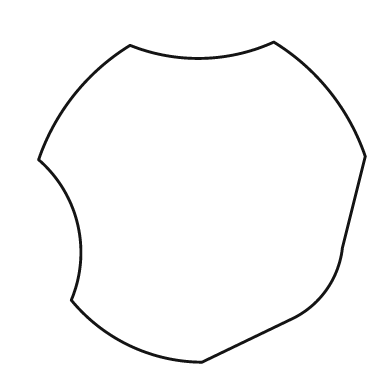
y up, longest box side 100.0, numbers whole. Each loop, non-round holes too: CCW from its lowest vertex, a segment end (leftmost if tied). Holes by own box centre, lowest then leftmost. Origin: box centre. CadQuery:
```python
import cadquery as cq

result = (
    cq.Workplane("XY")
    .moveTo(0.0, -49.0)
    .lineTo(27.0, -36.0)
    .threePointArc((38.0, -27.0), (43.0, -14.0))
    .lineTo(50.0, 14.0)
    .threePointArc((39.0, 34.0), (22.0, 49.0))
    .threePointArc((0.0, 44.0), (-22.0, 48.0))
    .threePointArc((-39.0, 33.0), (-50.0, 13.0))
    .threePointArc((-38.0, -7.0), (-40.0, -30.0))
    .threePointArc((-22.0, -44.0), (0.0, -49.0))
    .close()
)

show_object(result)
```